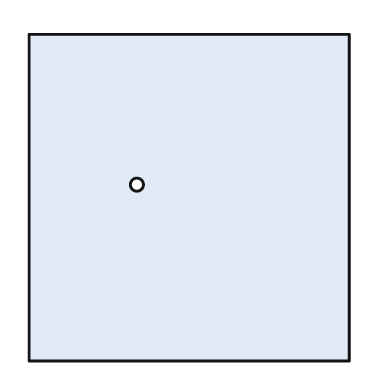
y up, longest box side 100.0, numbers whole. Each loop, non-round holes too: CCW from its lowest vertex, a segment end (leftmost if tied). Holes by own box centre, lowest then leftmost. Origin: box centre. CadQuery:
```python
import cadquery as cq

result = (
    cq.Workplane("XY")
    .moveTo(-49.0, -50.0)
    .lineTo(49.0, -50.0)
    .lineTo(49.0, 50.0)
    .lineTo(-49.0, 50.0)
    .close()
    .moveTo(-16.0, 4.0)
    .circle(2.0)
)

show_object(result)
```